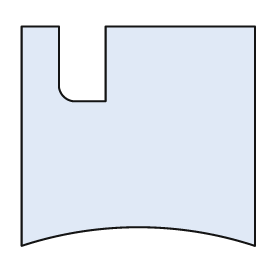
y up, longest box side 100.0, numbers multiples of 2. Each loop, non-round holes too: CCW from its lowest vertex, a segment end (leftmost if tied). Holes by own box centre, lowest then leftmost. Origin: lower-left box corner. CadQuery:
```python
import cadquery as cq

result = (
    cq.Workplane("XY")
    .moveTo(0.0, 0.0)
    .threePointArc((50.0, 8.0), (100.0, 0.0))
    .lineTo(100.0, 94.0)
    .lineTo(36.0, 94.0)
    .lineTo(36.0, 62.0)
    .lineTo(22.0, 62.0)
    .threePointArc((18.0, 64.0), (16.0, 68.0))
    .lineTo(16.0, 94.0)
    .lineTo(0.0, 94.0)
    .close()
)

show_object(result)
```